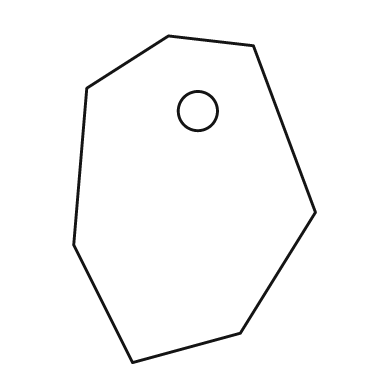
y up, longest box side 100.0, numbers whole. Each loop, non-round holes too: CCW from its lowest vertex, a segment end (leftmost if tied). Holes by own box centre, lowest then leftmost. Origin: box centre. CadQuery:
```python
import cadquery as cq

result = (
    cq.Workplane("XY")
    .moveTo(-19.0, -50.0)
    .lineTo(14.0, -41.0)
    .lineTo(37.0, -4.0)
    .lineTo(18.0, 47.0)
    .lineTo(-8.0, 50.0)
    .lineTo(-33.0, 34.0)
    .lineTo(-37.0, -14.0)
    .close()
    .moveTo(1.0, 27.0)
    .circle(6.0)
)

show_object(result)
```